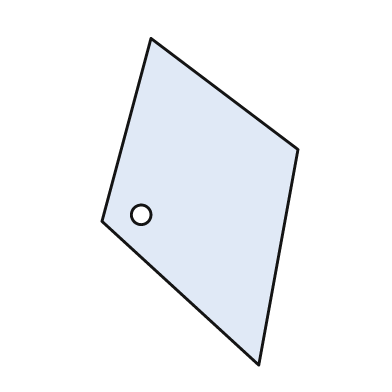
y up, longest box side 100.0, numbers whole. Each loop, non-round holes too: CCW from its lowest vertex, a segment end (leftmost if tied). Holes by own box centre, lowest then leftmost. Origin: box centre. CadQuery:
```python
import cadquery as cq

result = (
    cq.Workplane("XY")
    .moveTo(18.0, -50.0)
    .lineTo(30.0, 16.0)
    .lineTo(-15.0, 50.0)
    .lineTo(-30.0, -6.0)
    .close()
    .moveTo(-18.0, -4.0)
    .circle(3.0)
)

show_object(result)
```